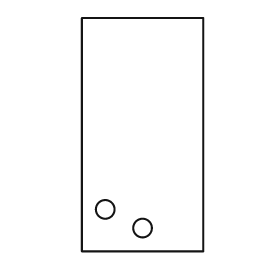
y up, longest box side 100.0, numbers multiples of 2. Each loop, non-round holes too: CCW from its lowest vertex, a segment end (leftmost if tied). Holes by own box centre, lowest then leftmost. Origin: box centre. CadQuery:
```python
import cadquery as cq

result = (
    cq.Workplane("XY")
    .moveTo(-26.0, -50.0)
    .lineTo(26.0, -50.0)
    .lineTo(26.0, 50.0)
    .lineTo(-26.0, 50.0)
    .close()
    .moveTo(0.0, -40.0)
    .circle(4.0)
    .moveTo(-16.0, -32.0)
    .circle(4.0)
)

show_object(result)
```